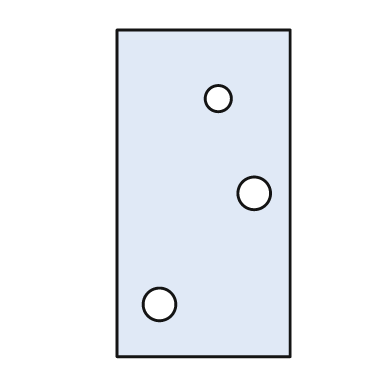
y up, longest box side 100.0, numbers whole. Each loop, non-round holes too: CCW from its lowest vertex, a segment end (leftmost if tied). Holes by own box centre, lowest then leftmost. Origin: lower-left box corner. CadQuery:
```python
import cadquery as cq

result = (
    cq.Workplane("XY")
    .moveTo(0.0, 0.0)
    .lineTo(53.0, 0.0)
    .lineTo(53.0, 100.0)
    .lineTo(0.0, 100.0)
    .close()
    .moveTo(13.0, 16.0)
    .circle(5.0)
    .moveTo(42.0, 50.0)
    .circle(5.0)
    .moveTo(31.0, 79.0)
    .circle(4.0)
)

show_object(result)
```